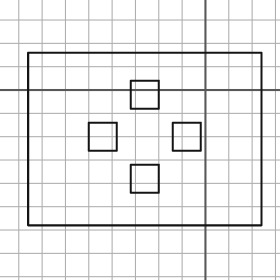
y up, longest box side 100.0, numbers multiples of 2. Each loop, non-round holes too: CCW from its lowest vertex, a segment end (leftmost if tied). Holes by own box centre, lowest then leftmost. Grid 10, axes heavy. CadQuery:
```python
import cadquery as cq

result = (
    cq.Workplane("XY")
    .moveTo(-76.0, -58.0)
    .lineTo(24.0, -58.0)
    .lineTo(24.0, 16.0)
    .lineTo(-76.0, 16.0)
    .close()
    .moveTo(-32.0, -44.0)
    .lineTo(-20.0, -44.0)
    .lineTo(-20.0, -32.0)
    .lineTo(-32.0, -32.0)
    .close()
    .moveTo(-50.0, -26.0)
    .lineTo(-38.0, -26.0)
    .lineTo(-38.0, -14.0)
    .lineTo(-50.0, -14.0)
    .close()
    .moveTo(-14.0, -26.0)
    .lineTo(-2.0, -26.0)
    .lineTo(-2.0, -14.0)
    .lineTo(-14.0, -14.0)
    .close()
    .moveTo(-32.0, -8.0)
    .lineTo(-20.0, -8.0)
    .lineTo(-20.0, 4.0)
    .lineTo(-32.0, 4.0)
    .close()
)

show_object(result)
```